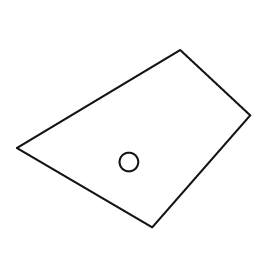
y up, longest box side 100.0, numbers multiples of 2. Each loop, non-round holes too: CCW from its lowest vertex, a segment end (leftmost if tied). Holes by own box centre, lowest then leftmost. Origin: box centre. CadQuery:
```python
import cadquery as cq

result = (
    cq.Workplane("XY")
    .moveTo(8.0, -38.0)
    .lineTo(50.0, 10.0)
    .lineTo(20.0, 38.0)
    .lineTo(-50.0, -4.0)
    .close()
    .moveTo(-2.0, -10.0)
    .circle(4.0)
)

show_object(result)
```